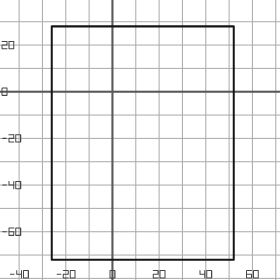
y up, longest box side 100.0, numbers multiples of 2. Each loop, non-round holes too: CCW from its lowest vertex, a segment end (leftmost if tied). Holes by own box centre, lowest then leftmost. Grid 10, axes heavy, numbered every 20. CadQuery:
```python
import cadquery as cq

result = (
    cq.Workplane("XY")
    .moveTo(-26.0, -72.0)
    .lineTo(52.0, -72.0)
    .lineTo(52.0, 28.0)
    .lineTo(-26.0, 28.0)
    .close()
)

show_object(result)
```